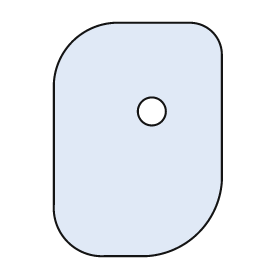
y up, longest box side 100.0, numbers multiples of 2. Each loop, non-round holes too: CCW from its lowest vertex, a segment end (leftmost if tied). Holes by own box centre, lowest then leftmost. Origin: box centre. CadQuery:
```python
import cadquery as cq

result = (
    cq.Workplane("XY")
    .moveTo(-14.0, -50.0)
    .lineTo(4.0, -50.0)
    .threePointArc((26.0, -40.0), (36.0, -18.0))
    .lineTo(36.0, 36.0)
    .threePointArc((32.0, 46.0), (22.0, 50.0))
    .lineTo(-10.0, 50.0)
    .threePointArc((-28.0, 42.0), (-36.0, 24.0))
    .lineTo(-36.0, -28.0)
    .threePointArc((-30.0, -44.0), (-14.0, -50.0))
    .close()
    .moveTo(6.0, 12.0)
    .circle(6.0)
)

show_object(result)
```